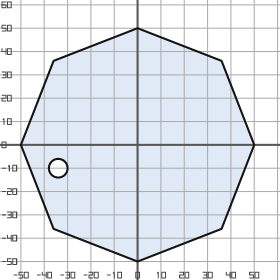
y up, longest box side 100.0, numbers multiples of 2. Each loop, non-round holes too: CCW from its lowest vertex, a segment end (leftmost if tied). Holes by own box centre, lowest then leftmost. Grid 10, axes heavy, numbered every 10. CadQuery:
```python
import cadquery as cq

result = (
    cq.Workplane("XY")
    .moveTo(0.0, -50.0)
    .lineTo(36.0, -36.0)
    .lineTo(50.0, 0.0)
    .lineTo(36.0, 36.0)
    .lineTo(0.0, 50.0)
    .lineTo(-36.0, 36.0)
    .lineTo(-50.0, 0.0)
    .lineTo(-36.0, -36.0)
    .close()
    .moveTo(-34.0, -10.0)
    .circle(4.0)
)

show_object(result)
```